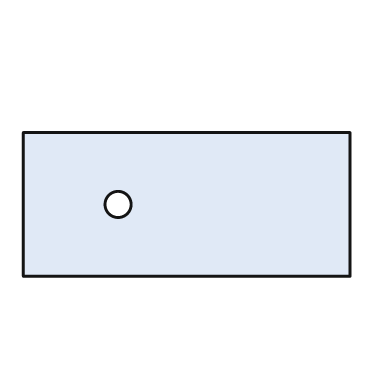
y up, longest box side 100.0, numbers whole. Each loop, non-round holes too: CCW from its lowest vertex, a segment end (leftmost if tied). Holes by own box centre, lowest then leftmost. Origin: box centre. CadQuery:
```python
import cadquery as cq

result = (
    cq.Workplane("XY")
    .moveTo(-50.0, -22.0)
    .lineTo(50.0, -22.0)
    .lineTo(50.0, 22.0)
    .lineTo(-50.0, 22.0)
    .close()
    .moveTo(-21.0, 0.0)
    .circle(4.0)
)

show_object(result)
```